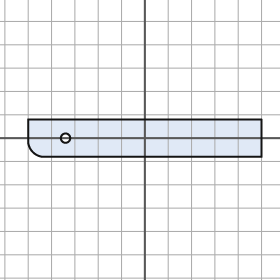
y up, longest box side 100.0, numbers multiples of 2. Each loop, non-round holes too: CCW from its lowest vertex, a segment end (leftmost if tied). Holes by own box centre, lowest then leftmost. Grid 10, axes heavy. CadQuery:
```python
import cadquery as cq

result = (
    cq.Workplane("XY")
    .moveTo(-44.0, -8.0)
    .lineTo(50.0, -8.0)
    .lineTo(50.0, 8.0)
    .lineTo(-50.0, 8.0)
    .lineTo(-50.0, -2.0)
    .threePointArc((-48.0, -6.0), (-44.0, -8.0))
    .close()
    .moveTo(-34.0, 0.0)
    .circle(2.0)
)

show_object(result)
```